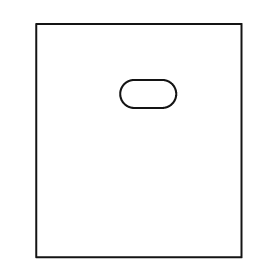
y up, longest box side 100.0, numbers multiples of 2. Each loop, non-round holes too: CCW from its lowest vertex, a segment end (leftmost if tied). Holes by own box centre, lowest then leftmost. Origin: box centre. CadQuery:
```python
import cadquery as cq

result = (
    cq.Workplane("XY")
    .moveTo(-44.0, -50.0)
    .lineTo(44.0, -50.0)
    .lineTo(44.0, 50.0)
    .lineTo(-44.0, 50.0)
    .close()
    .moveTo(-2.0, 14.0)
    .lineTo(10.0, 14.0)
    .threePointArc((16.0, 20.0), (10.0, 26.0))
    .lineTo(-2.0, 26.0)
    .threePointArc((-8.0, 20.0), (-2.0, 14.0))
    .close()
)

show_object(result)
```